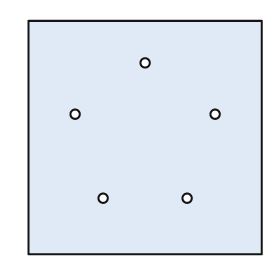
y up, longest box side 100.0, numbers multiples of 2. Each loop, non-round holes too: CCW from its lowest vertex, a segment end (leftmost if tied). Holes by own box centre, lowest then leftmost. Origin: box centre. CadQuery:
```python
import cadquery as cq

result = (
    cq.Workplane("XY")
    .moveTo(-50.0, -50.0)
    .lineTo(50.0, -50.0)
    .lineTo(50.0, 50.0)
    .lineTo(-50.0, 50.0)
    .close()
    .moveTo(-18.0, -26.0)
    .circle(2.0)
    .moveTo(18.0, -26.0)
    .circle(2.0)
    .moveTo(-30.0, 10.0)
    .circle(2.0)
    .moveTo(30.0, 10.0)
    .circle(2.0)
    .moveTo(0.0, 32.0)
    .circle(2.0)
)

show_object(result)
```